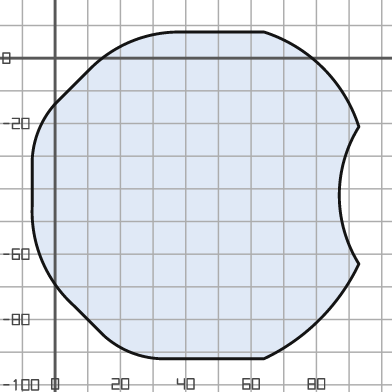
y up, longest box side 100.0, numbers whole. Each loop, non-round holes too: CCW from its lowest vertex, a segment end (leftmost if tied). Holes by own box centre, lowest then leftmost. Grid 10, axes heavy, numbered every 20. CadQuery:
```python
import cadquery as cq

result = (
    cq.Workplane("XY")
    .moveTo(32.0, -92.0)
    .lineTo(64.0, -92.0)
    .threePointArc((81.0, -80.0), (93.0, -63.0))
    .threePointArc((87.0, -42.0), (93.0, -21.0))
    .threePointArc((82.0, -3.0), (64.0, 8.0))
    .lineTo(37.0, 8.0)
    .threePointArc((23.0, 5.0), (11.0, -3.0))
    .lineTo(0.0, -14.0)
    .threePointArc((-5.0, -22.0), (-7.0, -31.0))
    .lineTo(-7.0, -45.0)
    .threePointArc((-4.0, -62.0), (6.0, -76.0))
    .lineTo(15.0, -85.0)
    .threePointArc((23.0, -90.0), (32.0, -92.0))
    .close()
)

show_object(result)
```